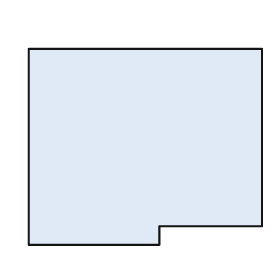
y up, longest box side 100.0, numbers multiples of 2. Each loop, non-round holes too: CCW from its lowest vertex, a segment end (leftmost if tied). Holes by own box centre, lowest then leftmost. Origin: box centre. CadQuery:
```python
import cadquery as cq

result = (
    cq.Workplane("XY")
    .moveTo(-50.0, -42.0)
    .lineTo(6.0, -42.0)
    .lineTo(6.0, -34.0)
    .lineTo(50.0, -34.0)
    .lineTo(50.0, 42.0)
    .lineTo(-50.0, 42.0)
    .close()
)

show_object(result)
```